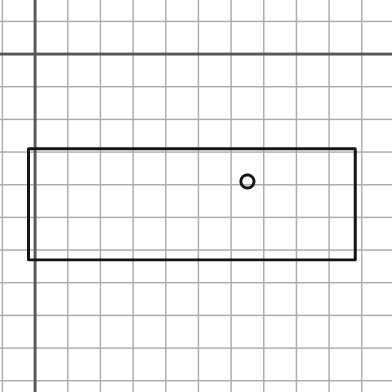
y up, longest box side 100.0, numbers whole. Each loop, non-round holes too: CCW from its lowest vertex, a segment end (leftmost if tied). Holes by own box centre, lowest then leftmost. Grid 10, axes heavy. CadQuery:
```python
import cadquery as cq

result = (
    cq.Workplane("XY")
    .moveTo(-2.0, -63.0)
    .lineTo(98.0, -63.0)
    .lineTo(98.0, -29.0)
    .lineTo(-2.0, -29.0)
    .close()
    .moveTo(65.0, -39.0)
    .circle(2.0)
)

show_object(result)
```